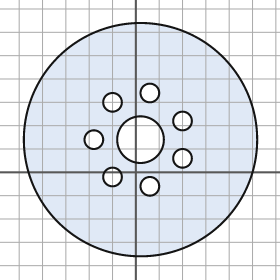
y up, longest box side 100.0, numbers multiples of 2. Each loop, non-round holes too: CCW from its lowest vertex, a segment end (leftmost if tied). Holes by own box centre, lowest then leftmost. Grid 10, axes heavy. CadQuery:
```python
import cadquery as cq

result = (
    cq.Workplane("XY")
    .moveTo(2.0, 14.0)
    .circle(50.0)
    .moveTo(6.0, -6.0)
    .circle(4.0)
    .moveTo(-10.0, -2.0)
    .circle(4.0)
    .moveTo(20.0, 6.0)
    .circle(4.0)
    .moveTo(-18.0, 14.0)
    .circle(4.0)
    .moveTo(2.0, 14.0)
    .circle(10.0)
    .moveTo(20.0, 22.0)
    .circle(4.0)
    .moveTo(-10.0, 30.0)
    .circle(4.0)
    .moveTo(6.0, 34.0)
    .circle(4.0)
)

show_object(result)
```